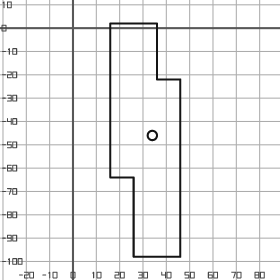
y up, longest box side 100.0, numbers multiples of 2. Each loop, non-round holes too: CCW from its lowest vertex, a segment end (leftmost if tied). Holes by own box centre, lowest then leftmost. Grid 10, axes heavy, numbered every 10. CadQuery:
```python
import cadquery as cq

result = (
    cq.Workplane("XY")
    .moveTo(26.0, -98.0)
    .lineTo(46.0, -98.0)
    .lineTo(46.0, -22.0)
    .lineTo(36.0, -22.0)
    .lineTo(36.0, 2.0)
    .lineTo(16.0, 2.0)
    .lineTo(16.0, -64.0)
    .lineTo(26.0, -64.0)
    .close()
    .moveTo(34.0, -46.0)
    .circle(2.0)
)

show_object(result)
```